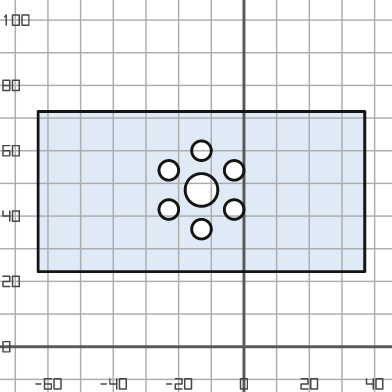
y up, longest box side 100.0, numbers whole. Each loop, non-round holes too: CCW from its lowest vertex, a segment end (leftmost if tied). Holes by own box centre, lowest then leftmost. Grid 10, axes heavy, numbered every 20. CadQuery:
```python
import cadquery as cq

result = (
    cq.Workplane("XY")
    .moveTo(-63.0, 23.0)
    .lineTo(37.0, 23.0)
    .lineTo(37.0, 72.0)
    .lineTo(-63.0, 72.0)
    .close()
    .moveTo(-13.0, 36.0)
    .circle(3.0)
    .moveTo(-23.0, 42.0)
    .circle(3.0)
    .moveTo(-3.0, 42.0)
    .circle(3.0)
    .moveTo(-13.0, 48.0)
    .circle(5.0)
    .moveTo(-23.0, 54.0)
    .circle(3.0)
    .moveTo(-3.0, 54.0)
    .circle(3.0)
    .moveTo(-13.0, 60.0)
    .circle(3.0)
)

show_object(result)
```